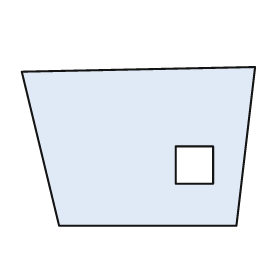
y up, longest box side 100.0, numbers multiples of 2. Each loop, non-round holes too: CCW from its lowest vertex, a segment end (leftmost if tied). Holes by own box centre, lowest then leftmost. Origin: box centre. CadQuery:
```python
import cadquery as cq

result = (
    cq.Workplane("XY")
    .moveTo(-34.0, -34.0)
    .lineTo(42.0, -34.0)
    .lineTo(50.0, 34.0)
    .lineTo(-50.0, 32.0)
    .close()
    .moveTo(16.0, -16.0)
    .lineTo(32.0, -16.0)
    .lineTo(32.0, 0.0)
    .lineTo(16.0, 0.0)
    .close()
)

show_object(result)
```